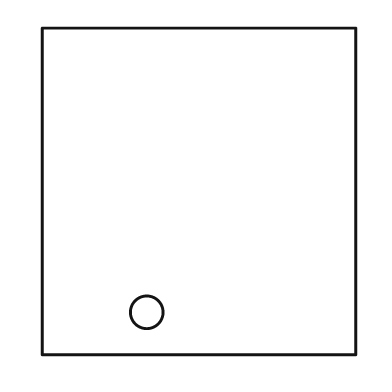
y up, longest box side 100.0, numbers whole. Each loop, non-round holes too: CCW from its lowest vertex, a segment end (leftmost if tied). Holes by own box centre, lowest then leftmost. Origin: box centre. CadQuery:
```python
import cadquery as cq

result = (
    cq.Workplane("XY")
    .moveTo(-48.0, -50.0)
    .lineTo(48.0, -50.0)
    .lineTo(48.0, 50.0)
    .lineTo(-48.0, 50.0)
    .close()
    .moveTo(-16.0, -37.0)
    .circle(5.0)
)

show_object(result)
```